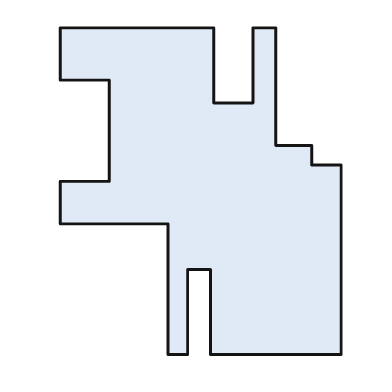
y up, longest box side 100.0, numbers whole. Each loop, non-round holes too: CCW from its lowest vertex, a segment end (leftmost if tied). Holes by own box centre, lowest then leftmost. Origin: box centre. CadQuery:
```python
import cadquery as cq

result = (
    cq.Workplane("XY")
    .moveTo(-10.0, -50.0)
    .lineTo(-4.0, -50.0)
    .lineTo(-4.0, -24.0)
    .lineTo(3.0, -24.0)
    .lineTo(3.0, -50.0)
    .lineTo(43.0, -50.0)
    .lineTo(43.0, 8.0)
    .lineTo(34.0, 8.0)
    .lineTo(34.0, 14.0)
    .lineTo(23.0, 14.0)
    .lineTo(23.0, 50.0)
    .lineTo(16.0, 50.0)
    .lineTo(16.0, 27.0)
    .lineTo(4.0, 27.0)
    .lineTo(4.0, 50.0)
    .lineTo(-43.0, 50.0)
    .lineTo(-43.0, 34.0)
    .lineTo(-28.0, 34.0)
    .lineTo(-28.0, 3.0)
    .lineTo(-43.0, 3.0)
    .lineTo(-43.0, -10.0)
    .lineTo(-10.0, -10.0)
    .close()
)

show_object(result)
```